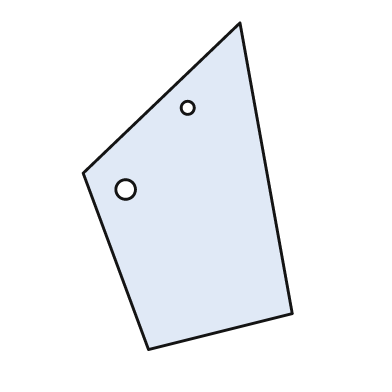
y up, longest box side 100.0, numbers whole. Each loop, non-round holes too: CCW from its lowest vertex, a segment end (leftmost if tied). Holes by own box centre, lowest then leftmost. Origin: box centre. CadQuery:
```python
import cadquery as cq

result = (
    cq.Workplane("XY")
    .moveTo(-12.0, -50.0)
    .lineTo(32.0, -39.0)
    .lineTo(16.0, 50.0)
    .lineTo(-32.0, 4.0)
    .close()
    .moveTo(-19.0, -1.0)
    .circle(3.0)
    .moveTo(0.0, 24.0)
    .circle(2.0)
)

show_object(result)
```